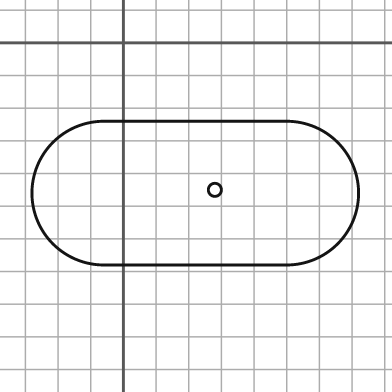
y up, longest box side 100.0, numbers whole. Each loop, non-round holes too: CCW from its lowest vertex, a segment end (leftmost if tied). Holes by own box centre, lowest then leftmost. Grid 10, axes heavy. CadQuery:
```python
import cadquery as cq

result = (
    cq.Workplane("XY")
    .moveTo(-6.0, -68.0)
    .lineTo(50.0, -68.0)
    .threePointArc((72.0, -46.0), (50.0, -24.0))
    .lineTo(-6.0, -24.0)
    .threePointArc((-28.0, -46.0), (-6.0, -68.0))
    .close()
    .moveTo(28.0, -45.0)
    .circle(2.0)
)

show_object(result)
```